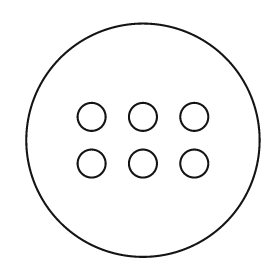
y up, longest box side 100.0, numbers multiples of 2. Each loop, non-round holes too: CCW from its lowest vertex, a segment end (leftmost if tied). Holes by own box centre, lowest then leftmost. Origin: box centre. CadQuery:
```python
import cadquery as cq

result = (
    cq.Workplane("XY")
    .moveTo(0.0, 0.0)
    .circle(50.0)
    .moveTo(-22.0, -10.0)
    .circle(6.0)
    .moveTo(0.0, -10.0)
    .circle(6.0)
    .moveTo(22.0, -10.0)
    .circle(6.0)
    .moveTo(-22.0, 10.0)
    .circle(6.0)
    .moveTo(0.0, 10.0)
    .circle(6.0)
    .moveTo(22.0, 10.0)
    .circle(6.0)
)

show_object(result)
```